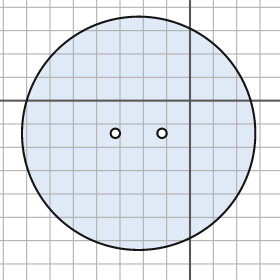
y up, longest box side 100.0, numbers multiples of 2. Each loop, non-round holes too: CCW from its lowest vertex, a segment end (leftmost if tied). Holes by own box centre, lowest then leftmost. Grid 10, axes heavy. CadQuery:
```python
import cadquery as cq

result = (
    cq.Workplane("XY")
    .moveTo(-22.0, -14.0)
    .circle(50.0)
    .moveTo(-32.0, -14.0)
    .circle(2.0)
    .moveTo(-12.0, -14.0)
    .circle(2.0)
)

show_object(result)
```